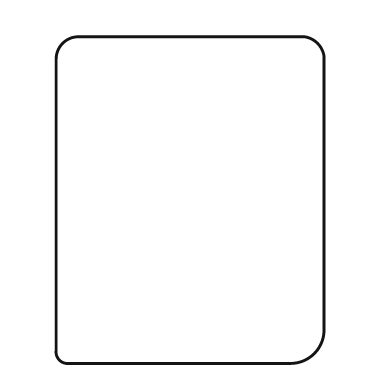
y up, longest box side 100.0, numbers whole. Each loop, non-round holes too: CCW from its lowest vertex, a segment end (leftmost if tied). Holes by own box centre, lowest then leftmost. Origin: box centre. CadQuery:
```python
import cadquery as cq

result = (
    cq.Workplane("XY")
    .moveTo(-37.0, -50.0)
    .lineTo(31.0, -50.0)
    .threePointArc((38.0, -47.0), (41.0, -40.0))
    .lineTo(41.0, 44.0)
    .threePointArc((39.0, 48.0), (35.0, 50.0))
    .lineTo(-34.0, 50.0)
    .threePointArc((-39.0, 48.0), (-41.0, 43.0))
    .lineTo(-41.0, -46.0)
    .threePointArc((-40.0, -49.0), (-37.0, -50.0))
    .close()
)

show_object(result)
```